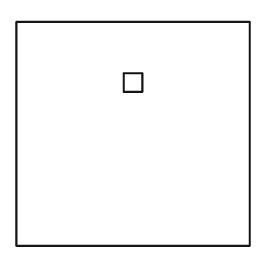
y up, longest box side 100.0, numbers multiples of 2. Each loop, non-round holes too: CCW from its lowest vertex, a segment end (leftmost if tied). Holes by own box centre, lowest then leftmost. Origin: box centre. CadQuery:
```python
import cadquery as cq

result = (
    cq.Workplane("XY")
    .moveTo(-50.0, -48.0)
    .lineTo(50.0, -48.0)
    .lineTo(50.0, 48.0)
    .lineTo(-50.0, 48.0)
    .close()
    .moveTo(-4.0, 18.0)
    .lineTo(4.0, 18.0)
    .lineTo(4.0, 26.0)
    .lineTo(-4.0, 26.0)
    .close()
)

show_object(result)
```